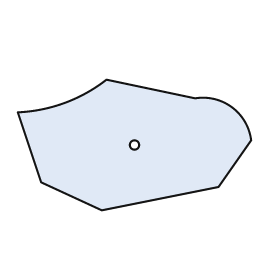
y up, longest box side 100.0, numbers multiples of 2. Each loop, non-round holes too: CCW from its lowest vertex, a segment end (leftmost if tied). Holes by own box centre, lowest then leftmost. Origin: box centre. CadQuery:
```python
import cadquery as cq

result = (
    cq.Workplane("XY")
    .moveTo(-14.0, -28.0)
    .lineTo(36.0, -18.0)
    .lineTo(50.0, 2.0)
    .threePointArc((42.0, 16.0), (26.0, 20.0))
    .lineTo(-12.0, 28.0)
    .threePointArc((-30.0, 18.0), (-50.0, 14.0))
    .lineTo(-40.0, -16.0)
    .close()
    .moveTo(0.0, 0.0)
    .circle(2.0)
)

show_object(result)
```